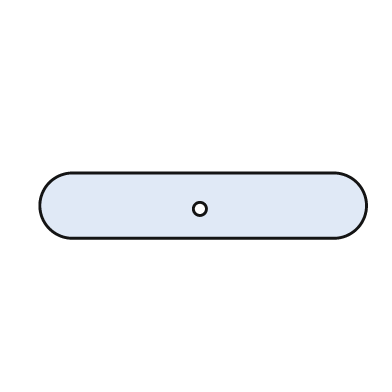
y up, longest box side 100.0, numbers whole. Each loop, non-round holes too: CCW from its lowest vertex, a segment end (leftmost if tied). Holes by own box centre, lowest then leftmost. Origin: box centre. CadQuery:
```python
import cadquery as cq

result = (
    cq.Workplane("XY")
    .moveTo(-40.0, -10.0)
    .lineTo(40.0, -10.0)
    .threePointArc((50.0, 0.0), (40.0, 10.0))
    .lineTo(-40.0, 10.0)
    .threePointArc((-50.0, 0.0), (-40.0, -10.0))
    .close()
    .moveTo(-1.0, -1.0)
    .circle(2.0)
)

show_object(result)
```